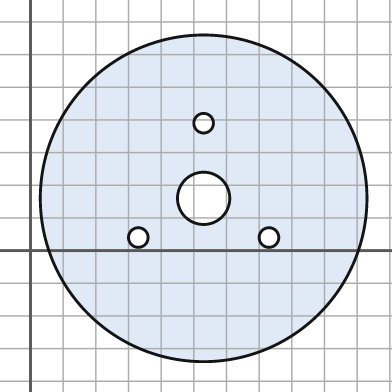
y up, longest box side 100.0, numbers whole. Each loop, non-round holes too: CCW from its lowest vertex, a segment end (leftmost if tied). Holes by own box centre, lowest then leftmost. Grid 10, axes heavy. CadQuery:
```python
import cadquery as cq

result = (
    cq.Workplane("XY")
    .moveTo(53.0, 16.0)
    .circle(50.0)
    .moveTo(33.0, 4.0)
    .circle(3.0)
    .moveTo(73.0, 4.0)
    .circle(3.0)
    .moveTo(53.0, 16.0)
    .circle(8.0)
    .moveTo(53.0, 39.0)
    .circle(3.0)
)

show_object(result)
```